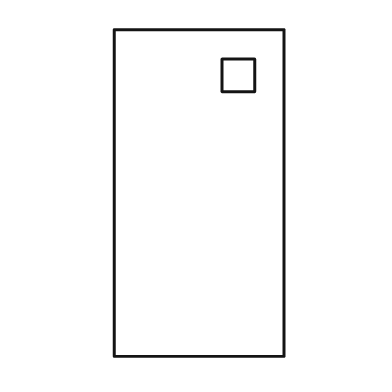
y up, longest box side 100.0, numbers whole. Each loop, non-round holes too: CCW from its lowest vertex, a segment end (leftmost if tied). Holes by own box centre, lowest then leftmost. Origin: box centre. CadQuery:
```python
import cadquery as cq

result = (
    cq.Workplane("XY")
    .moveTo(-26.0, -50.0)
    .lineTo(26.0, -50.0)
    .lineTo(26.0, 50.0)
    .lineTo(-26.0, 50.0)
    .close()
    .moveTo(7.0, 31.0)
    .lineTo(17.0, 31.0)
    .lineTo(17.0, 41.0)
    .lineTo(7.0, 41.0)
    .close()
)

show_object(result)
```